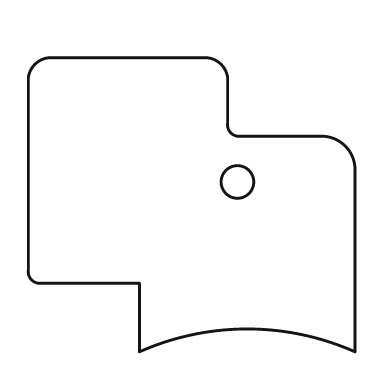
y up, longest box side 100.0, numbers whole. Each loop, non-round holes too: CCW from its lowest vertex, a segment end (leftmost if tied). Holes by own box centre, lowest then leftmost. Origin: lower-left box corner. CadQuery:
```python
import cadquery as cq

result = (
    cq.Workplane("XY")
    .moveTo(34.0, 0.0)
    .threePointArc((67.0, 7.0), (100.0, 0.0))
    .lineTo(100.0, 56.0)
    .threePointArc((97.0, 63.0), (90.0, 66.0))
    .lineTo(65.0, 66.0)
    .threePointArc((62.0, 67.0), (61.0, 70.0))
    .lineTo(61.0, 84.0)
    .threePointArc((59.0, 88.0), (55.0, 90.0))
    .lineTo(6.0, 90.0)
    .threePointArc((2.0, 88.0), (0.0, 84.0))
    .lineTo(0.0, 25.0)
    .threePointArc((1.0, 22.0), (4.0, 21.0))
    .lineTo(34.0, 21.0)
    .close()
    .moveTo(64.0, 52.0)
    .circle(5.0)
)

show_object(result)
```